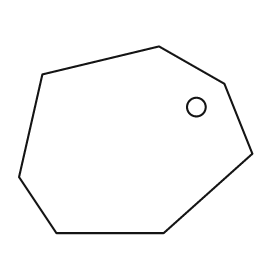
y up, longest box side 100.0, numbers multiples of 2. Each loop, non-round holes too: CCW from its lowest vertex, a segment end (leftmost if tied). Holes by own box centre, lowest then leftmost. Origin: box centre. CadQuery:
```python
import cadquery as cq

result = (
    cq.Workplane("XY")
    .moveTo(-34.0, -40.0)
    .lineTo(12.0, -40.0)
    .lineTo(50.0, -6.0)
    .lineTo(38.0, 24.0)
    .lineTo(10.0, 40.0)
    .lineTo(-40.0, 28.0)
    .lineTo(-50.0, -16.0)
    .close()
    .moveTo(26.0, 14.0)
    .circle(4.0)
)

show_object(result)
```